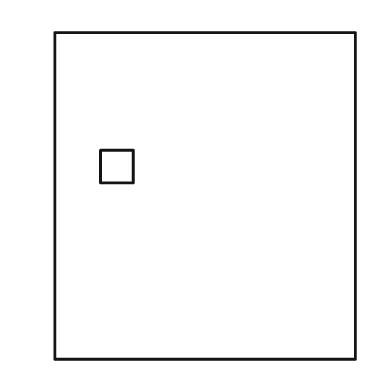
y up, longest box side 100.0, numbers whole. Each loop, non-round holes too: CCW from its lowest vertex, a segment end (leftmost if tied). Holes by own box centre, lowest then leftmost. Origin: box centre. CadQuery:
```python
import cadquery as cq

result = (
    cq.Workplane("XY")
    .moveTo(-46.0, -50.0)
    .lineTo(46.0, -50.0)
    .lineTo(46.0, 50.0)
    .lineTo(-46.0, 50.0)
    .close()
    .moveTo(-32.0, 4.0)
    .lineTo(-22.0, 4.0)
    .lineTo(-22.0, 14.0)
    .lineTo(-32.0, 14.0)
    .close()
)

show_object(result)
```